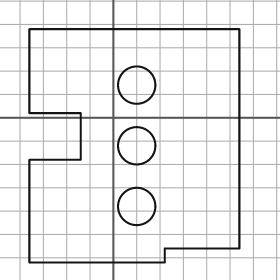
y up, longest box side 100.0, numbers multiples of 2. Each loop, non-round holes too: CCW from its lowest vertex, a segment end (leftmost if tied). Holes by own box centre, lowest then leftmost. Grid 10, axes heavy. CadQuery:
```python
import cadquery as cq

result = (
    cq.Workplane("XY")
    .moveTo(-36.0, -62.0)
    .lineTo(22.0, -62.0)
    .lineTo(22.0, -56.0)
    .lineTo(54.0, -56.0)
    .lineTo(54.0, 38.0)
    .lineTo(-36.0, 38.0)
    .lineTo(-36.0, 2.0)
    .lineTo(-14.0, 2.0)
    .lineTo(-14.0, -18.0)
    .lineTo(-36.0, -18.0)
    .close()
    .moveTo(10.0, -38.0)
    .circle(8.0)
    .moveTo(10.0, -12.0)
    .circle(8.0)
    .moveTo(10.0, 14.0)
    .circle(8.0)
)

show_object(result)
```